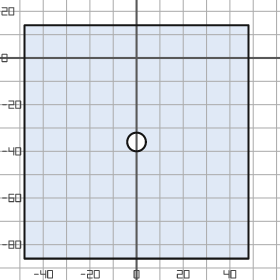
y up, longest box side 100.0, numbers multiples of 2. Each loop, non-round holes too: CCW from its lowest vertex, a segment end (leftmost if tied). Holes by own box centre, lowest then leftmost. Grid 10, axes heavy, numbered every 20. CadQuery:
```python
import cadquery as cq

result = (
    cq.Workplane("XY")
    .moveTo(-48.0, -86.0)
    .lineTo(48.0, -86.0)
    .lineTo(48.0, 14.0)
    .lineTo(-48.0, 14.0)
    .close()
    .moveTo(0.0, -36.0)
    .circle(4.0)
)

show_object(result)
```